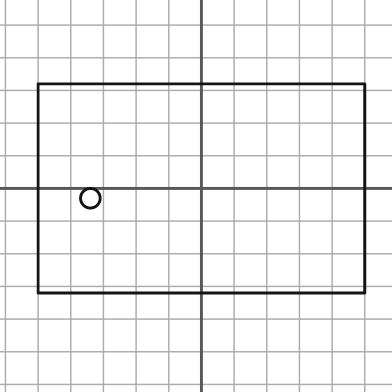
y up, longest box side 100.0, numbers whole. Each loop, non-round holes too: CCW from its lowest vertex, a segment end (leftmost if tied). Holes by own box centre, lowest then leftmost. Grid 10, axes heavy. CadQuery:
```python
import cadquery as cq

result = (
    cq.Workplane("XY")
    .moveTo(-50.0, -32.0)
    .lineTo(50.0, -32.0)
    .lineTo(50.0, 32.0)
    .lineTo(-50.0, 32.0)
    .close()
    .moveTo(-34.0, -3.0)
    .circle(3.0)
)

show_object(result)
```